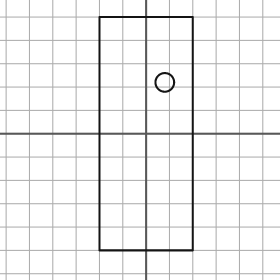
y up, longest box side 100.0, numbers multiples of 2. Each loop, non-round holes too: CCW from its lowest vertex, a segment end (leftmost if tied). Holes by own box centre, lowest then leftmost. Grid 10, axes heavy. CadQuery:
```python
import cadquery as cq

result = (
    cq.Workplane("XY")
    .moveTo(-20.0, -50.0)
    .lineTo(20.0, -50.0)
    .lineTo(20.0, 50.0)
    .lineTo(-20.0, 50.0)
    .close()
    .moveTo(8.0, 22.0)
    .circle(4.0)
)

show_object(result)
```